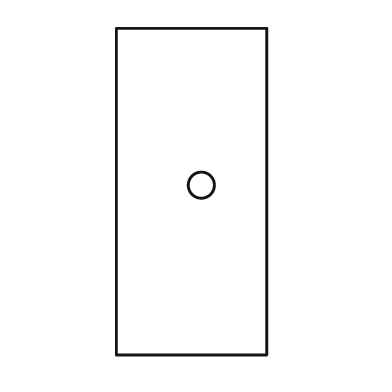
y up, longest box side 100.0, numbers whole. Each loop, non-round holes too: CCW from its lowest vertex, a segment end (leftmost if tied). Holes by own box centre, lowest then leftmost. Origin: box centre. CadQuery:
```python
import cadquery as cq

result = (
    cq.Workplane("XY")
    .moveTo(-23.0, -50.0)
    .lineTo(23.0, -50.0)
    .lineTo(23.0, 50.0)
    .lineTo(-23.0, 50.0)
    .close()
    .moveTo(3.0, 2.0)
    .circle(4.0)
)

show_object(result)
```